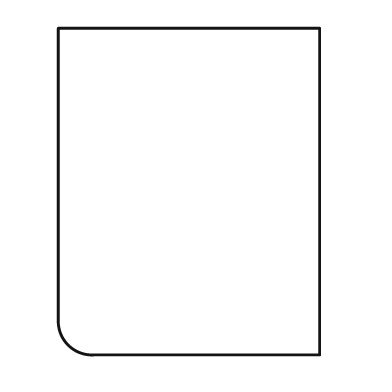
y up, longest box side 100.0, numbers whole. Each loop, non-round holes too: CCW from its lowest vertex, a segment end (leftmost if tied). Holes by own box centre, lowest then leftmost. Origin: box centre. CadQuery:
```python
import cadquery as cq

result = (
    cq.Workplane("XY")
    .moveTo(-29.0, -50.0)
    .lineTo(40.0, -50.0)
    .lineTo(40.0, 50.0)
    .lineTo(-40.0, 50.0)
    .lineTo(-40.0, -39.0)
    .threePointArc((-37.0, -47.0), (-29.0, -50.0))
    .close()
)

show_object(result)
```